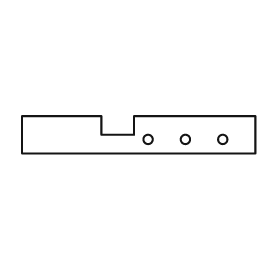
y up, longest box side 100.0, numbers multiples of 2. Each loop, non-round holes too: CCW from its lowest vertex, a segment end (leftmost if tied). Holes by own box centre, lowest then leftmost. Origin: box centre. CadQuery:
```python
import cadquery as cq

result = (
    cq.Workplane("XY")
    .moveTo(-50.0, -8.0)
    .lineTo(50.0, -8.0)
    .lineTo(50.0, 8.0)
    .lineTo(-2.0, 8.0)
    .lineTo(-2.0, 0.0)
    .lineTo(-16.0, 0.0)
    .lineTo(-16.0, 8.0)
    .lineTo(-50.0, 8.0)
    .close()
    .moveTo(4.0, -2.0)
    .circle(2.0)
    .moveTo(20.0, -2.0)
    .circle(2.0)
    .moveTo(36.0, -2.0)
    .circle(2.0)
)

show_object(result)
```